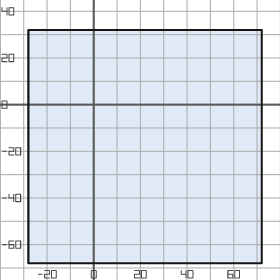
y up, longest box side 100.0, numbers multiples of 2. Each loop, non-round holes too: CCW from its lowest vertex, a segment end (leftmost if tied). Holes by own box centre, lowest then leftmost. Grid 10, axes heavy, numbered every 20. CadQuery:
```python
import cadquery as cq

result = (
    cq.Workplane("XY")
    .moveTo(-28.0, -68.0)
    .lineTo(72.0, -68.0)
    .lineTo(72.0, 32.0)
    .lineTo(-28.0, 32.0)
    .close()
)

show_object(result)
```